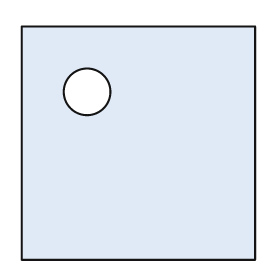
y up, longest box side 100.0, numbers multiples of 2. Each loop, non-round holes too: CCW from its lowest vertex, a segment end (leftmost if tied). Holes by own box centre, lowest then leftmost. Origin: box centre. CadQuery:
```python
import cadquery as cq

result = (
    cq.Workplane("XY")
    .moveTo(-50.0, -50.0)
    .lineTo(50.0, -50.0)
    .lineTo(50.0, 50.0)
    .lineTo(-50.0, 50.0)
    .close()
    .moveTo(-22.0, 22.0)
    .circle(10.0)
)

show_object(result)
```